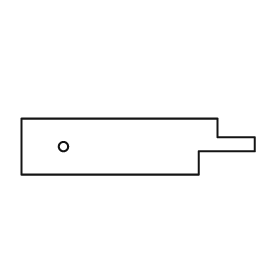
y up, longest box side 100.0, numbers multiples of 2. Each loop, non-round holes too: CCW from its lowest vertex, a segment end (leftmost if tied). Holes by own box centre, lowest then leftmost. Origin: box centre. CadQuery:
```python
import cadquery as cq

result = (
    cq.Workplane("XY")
    .moveTo(-50.0, -12.0)
    .lineTo(26.0, -12.0)
    .lineTo(26.0, -2.0)
    .lineTo(50.0, -2.0)
    .lineTo(50.0, 4.0)
    .lineTo(34.0, 4.0)
    .lineTo(34.0, 12.0)
    .lineTo(-50.0, 12.0)
    .close()
    .moveTo(-32.0, 0.0)
    .circle(2.0)
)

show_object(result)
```